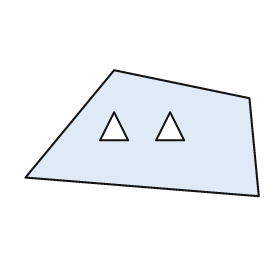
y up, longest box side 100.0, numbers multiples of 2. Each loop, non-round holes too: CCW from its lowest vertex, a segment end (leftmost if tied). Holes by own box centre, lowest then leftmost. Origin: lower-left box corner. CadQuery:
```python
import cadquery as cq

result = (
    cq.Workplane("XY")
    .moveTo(100.0, 0.0)
    .lineTo(96.0, 42.0)
    .lineTo(38.0, 54.0)
    .lineTo(0.0, 8.0)
    .close()
    .moveTo(32.0, 24.0)
    .lineTo(44.0, 24.0)
    .lineTo(38.0, 36.0)
    .close()
    .moveTo(56.0, 24.0)
    .lineTo(68.0, 24.0)
    .lineTo(62.0, 36.0)
    .close()
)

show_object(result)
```